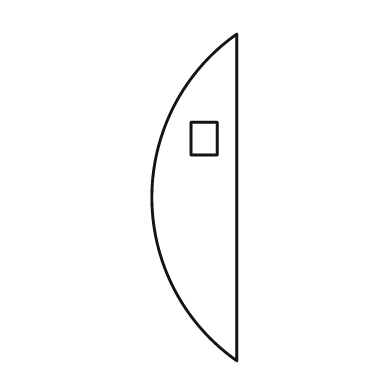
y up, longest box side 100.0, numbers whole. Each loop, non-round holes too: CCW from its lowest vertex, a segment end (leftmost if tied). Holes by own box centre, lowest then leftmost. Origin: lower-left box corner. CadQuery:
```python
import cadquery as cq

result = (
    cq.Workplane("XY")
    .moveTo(26.0, 0.0)
    .lineTo(26.0, 100.0)
    .threePointArc((0.0, 50.0), (26.0, 0.0))
    .close()
    .moveTo(12.0, 63.0)
    .lineTo(20.0, 63.0)
    .lineTo(20.0, 73.0)
    .lineTo(12.0, 73.0)
    .close()
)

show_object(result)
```